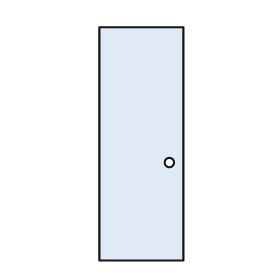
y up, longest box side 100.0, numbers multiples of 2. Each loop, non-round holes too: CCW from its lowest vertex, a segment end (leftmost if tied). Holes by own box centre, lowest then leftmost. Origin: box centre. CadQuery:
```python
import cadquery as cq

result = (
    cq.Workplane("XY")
    .moveTo(-18.0, -50.0)
    .lineTo(18.0, -50.0)
    .lineTo(18.0, 50.0)
    .lineTo(-18.0, 50.0)
    .close()
    .moveTo(12.0, -8.0)
    .circle(2.0)
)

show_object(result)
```